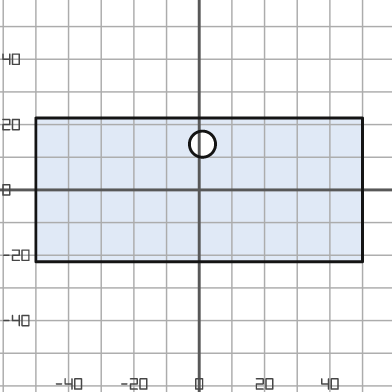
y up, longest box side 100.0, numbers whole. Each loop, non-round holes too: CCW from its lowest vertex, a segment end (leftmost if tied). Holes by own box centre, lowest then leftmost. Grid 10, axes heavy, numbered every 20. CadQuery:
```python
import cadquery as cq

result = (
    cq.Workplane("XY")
    .moveTo(-50.0, -22.0)
    .lineTo(50.0, -22.0)
    .lineTo(50.0, 22.0)
    .lineTo(-50.0, 22.0)
    .close()
    .moveTo(1.0, 14.0)
    .circle(4.0)
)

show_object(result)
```